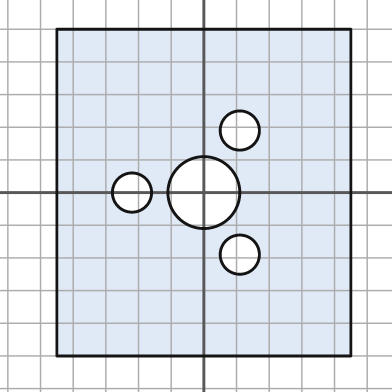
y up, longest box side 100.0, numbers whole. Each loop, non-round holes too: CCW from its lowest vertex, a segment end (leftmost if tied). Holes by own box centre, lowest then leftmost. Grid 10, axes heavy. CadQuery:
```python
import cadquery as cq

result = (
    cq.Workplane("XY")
    .moveTo(-45.0, -50.0)
    .lineTo(45.0, -50.0)
    .lineTo(45.0, 50.0)
    .lineTo(-45.0, 50.0)
    .close()
    .moveTo(11.0, -19.0)
    .circle(6.0)
    .moveTo(-22.0, 0.0)
    .circle(6.0)
    .moveTo(0.0, 0.0)
    .circle(11.0)
    .moveTo(11.0, 19.0)
    .circle(6.0)
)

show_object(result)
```